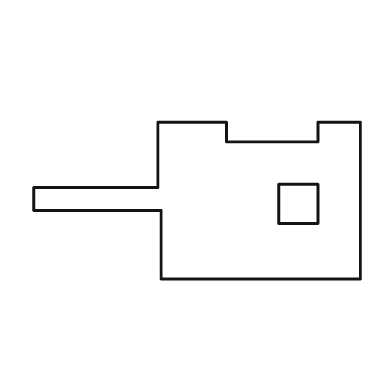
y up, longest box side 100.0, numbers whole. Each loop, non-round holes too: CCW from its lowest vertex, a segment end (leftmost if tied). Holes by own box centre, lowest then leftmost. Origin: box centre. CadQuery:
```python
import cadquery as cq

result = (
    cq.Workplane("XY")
    .moveTo(-11.0, -24.0)
    .lineTo(50.0, -24.0)
    .lineTo(50.0, 24.0)
    .lineTo(37.0, 24.0)
    .lineTo(37.0, 18.0)
    .lineTo(9.0, 18.0)
    .lineTo(9.0, 24.0)
    .lineTo(-12.0, 24.0)
    .lineTo(-12.0, 4.0)
    .lineTo(-50.0, 4.0)
    .lineTo(-50.0, -3.0)
    .lineTo(-11.0, -3.0)
    .close()
    .moveTo(25.0, -7.0)
    .lineTo(37.0, -7.0)
    .lineTo(37.0, 5.0)
    .lineTo(25.0, 5.0)
    .close()
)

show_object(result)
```